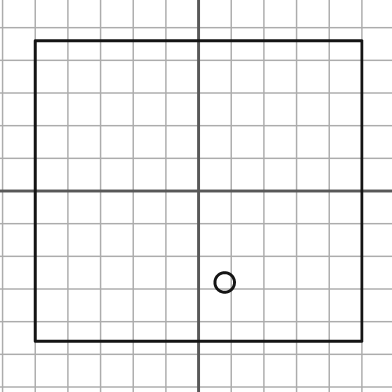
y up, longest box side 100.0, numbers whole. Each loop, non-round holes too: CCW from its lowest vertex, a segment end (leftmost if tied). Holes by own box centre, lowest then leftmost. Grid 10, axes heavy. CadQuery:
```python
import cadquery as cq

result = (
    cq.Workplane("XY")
    .moveTo(-50.0, -46.0)
    .lineTo(50.0, -46.0)
    .lineTo(50.0, 46.0)
    .lineTo(-50.0, 46.0)
    .close()
    .moveTo(8.0, -28.0)
    .circle(3.0)
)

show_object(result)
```